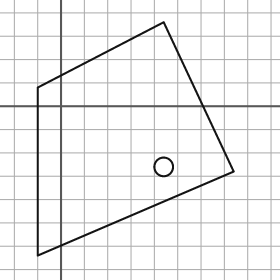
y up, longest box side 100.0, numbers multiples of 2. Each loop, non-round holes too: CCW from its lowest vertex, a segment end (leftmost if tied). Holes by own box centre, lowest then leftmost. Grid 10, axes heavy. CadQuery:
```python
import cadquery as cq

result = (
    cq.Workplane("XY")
    .moveTo(-10.0, -64.0)
    .lineTo(74.0, -28.0)
    .lineTo(44.0, 36.0)
    .lineTo(-10.0, 8.0)
    .close()
    .moveTo(44.0, -26.0)
    .circle(4.0)
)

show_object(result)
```